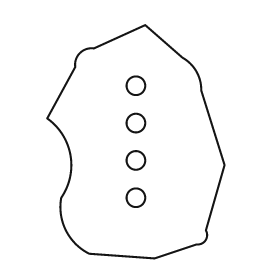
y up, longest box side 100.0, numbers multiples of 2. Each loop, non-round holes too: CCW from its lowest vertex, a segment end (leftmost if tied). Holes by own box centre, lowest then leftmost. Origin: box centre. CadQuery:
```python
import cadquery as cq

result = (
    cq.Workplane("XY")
    .moveTo(8.0, -50.0)
    .lineTo(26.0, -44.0)
    .threePointArc((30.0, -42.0), (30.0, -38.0))
    .lineTo(38.0, -10.0)
    .lineTo(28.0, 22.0)
    .threePointArc((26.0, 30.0), (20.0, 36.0))
    .lineTo(4.0, 50.0)
    .lineTo(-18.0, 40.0)
    .threePointArc((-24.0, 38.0), (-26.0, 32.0))
    .lineTo(-38.0, 10.0)
    .threePointArc((-28.0, -6.0), (-32.0, -24.0))
    .threePointArc((-30.0, -38.0), (-20.0, -48.0))
    .close()
    .moveTo(0.0, -24.0)
    .circle(4.0)
    .moveTo(0.0, -8.0)
    .circle(4.0)
    .moveTo(0.0, 8.0)
    .circle(4.0)
    .moveTo(0.0, 24.0)
    .circle(4.0)
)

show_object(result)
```